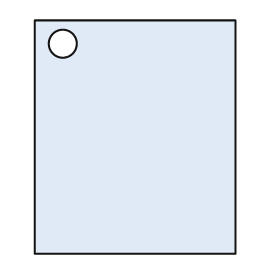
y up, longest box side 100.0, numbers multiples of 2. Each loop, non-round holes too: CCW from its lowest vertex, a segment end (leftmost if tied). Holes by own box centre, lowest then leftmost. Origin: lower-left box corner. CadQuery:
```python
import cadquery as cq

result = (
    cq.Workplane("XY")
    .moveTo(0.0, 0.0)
    .lineTo(86.0, 0.0)
    .lineTo(86.0, 100.0)
    .lineTo(0.0, 100.0)
    .close()
    .moveTo(12.0, 90.0)
    .circle(6.0)
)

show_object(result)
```